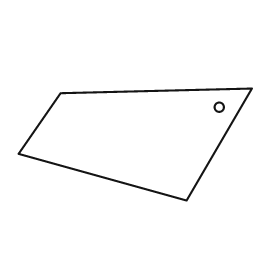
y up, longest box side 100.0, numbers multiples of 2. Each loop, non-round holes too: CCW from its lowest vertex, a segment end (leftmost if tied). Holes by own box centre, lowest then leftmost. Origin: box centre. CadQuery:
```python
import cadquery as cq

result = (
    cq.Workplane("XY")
    .moveTo(22.0, -24.0)
    .lineTo(50.0, 24.0)
    .lineTo(-32.0, 22.0)
    .lineTo(-50.0, -4.0)
    .close()
    .moveTo(36.0, 16.0)
    .circle(2.0)
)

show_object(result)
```